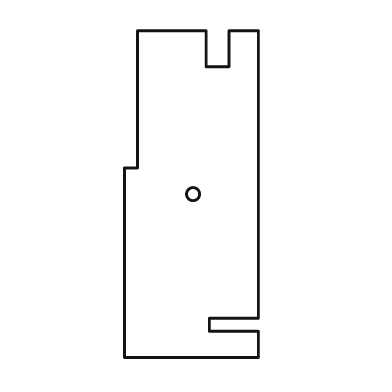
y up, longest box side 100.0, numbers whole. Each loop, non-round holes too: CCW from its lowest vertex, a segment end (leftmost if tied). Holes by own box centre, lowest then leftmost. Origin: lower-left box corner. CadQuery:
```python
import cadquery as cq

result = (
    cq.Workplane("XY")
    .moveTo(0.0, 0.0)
    .lineTo(41.0, 0.0)
    .lineTo(41.0, 8.0)
    .lineTo(26.0, 8.0)
    .lineTo(26.0, 12.0)
    .lineTo(41.0, 12.0)
    .lineTo(41.0, 100.0)
    .lineTo(32.0, 100.0)
    .lineTo(32.0, 89.0)
    .lineTo(25.0, 89.0)
    .lineTo(25.0, 100.0)
    .lineTo(4.0, 100.0)
    .lineTo(4.0, 58.0)
    .lineTo(0.0, 58.0)
    .close()
    .moveTo(21.0, 50.0)
    .circle(2.0)
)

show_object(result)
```